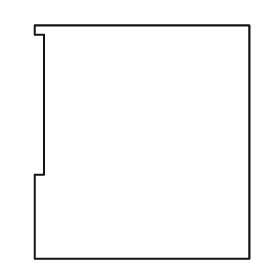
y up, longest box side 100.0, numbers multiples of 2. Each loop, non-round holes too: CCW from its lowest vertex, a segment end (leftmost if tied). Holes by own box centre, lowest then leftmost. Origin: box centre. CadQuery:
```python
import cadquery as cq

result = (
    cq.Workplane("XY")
    .moveTo(-46.0, -50.0)
    .lineTo(46.0, -50.0)
    .lineTo(46.0, 50.0)
    .lineTo(-46.0, 50.0)
    .lineTo(-46.0, 46.0)
    .lineTo(-42.0, 46.0)
    .lineTo(-42.0, -14.0)
    .lineTo(-46.0, -14.0)
    .close()
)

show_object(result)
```